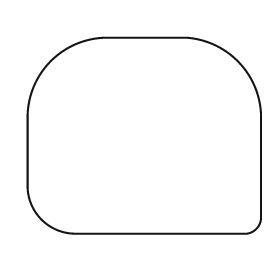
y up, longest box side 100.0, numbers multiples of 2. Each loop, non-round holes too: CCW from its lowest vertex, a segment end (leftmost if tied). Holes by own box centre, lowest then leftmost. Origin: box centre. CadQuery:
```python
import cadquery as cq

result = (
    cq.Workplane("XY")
    .moveTo(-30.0, -42.0)
    .lineTo(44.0, -42.0)
    .threePointArc((48.0, -40.0), (50.0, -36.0))
    .lineTo(50.0, 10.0)
    .threePointArc((40.0, 32.0), (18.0, 42.0))
    .lineTo(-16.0, 42.0)
    .threePointArc((-40.0, 32.0), (-50.0, 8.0))
    .lineTo(-50.0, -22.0)
    .threePointArc((-44.0, -36.0), (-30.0, -42.0))
    .close()
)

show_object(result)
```